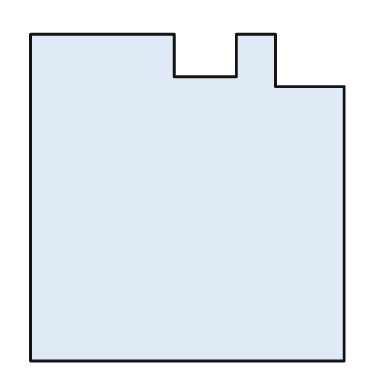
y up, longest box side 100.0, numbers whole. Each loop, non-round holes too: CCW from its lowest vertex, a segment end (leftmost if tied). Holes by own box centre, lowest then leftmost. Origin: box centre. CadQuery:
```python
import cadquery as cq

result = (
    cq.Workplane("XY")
    .moveTo(-48.0, -50.0)
    .lineTo(48.0, -50.0)
    .lineTo(48.0, 34.0)
    .lineTo(27.0, 34.0)
    .lineTo(27.0, 50.0)
    .lineTo(15.0, 50.0)
    .lineTo(15.0, 37.0)
    .lineTo(-4.0, 37.0)
    .lineTo(-4.0, 50.0)
    .lineTo(-48.0, 50.0)
    .close()
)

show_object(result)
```